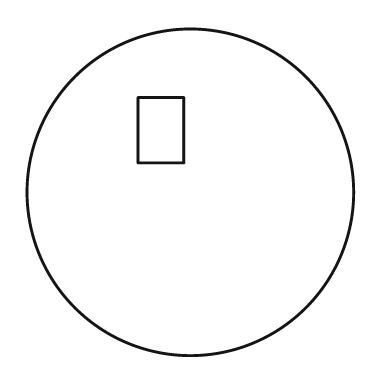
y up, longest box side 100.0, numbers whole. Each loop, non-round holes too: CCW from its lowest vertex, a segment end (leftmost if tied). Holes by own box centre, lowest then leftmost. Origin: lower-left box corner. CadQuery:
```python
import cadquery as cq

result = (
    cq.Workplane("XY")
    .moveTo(50.0, 50.0)
    .circle(50.0)
    .moveTo(34.0, 59.0)
    .lineTo(48.0, 59.0)
    .lineTo(48.0, 79.0)
    .lineTo(34.0, 79.0)
    .close()
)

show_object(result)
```